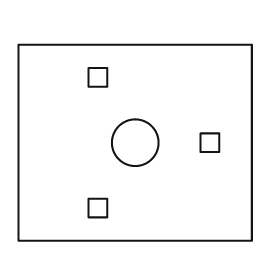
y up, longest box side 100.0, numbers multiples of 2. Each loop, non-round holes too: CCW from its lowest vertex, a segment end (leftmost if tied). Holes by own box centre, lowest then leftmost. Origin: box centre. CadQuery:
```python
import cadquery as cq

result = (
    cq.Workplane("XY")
    .moveTo(-50.0, -42.0)
    .lineTo(50.0, -42.0)
    .lineTo(50.0, 42.0)
    .lineTo(-50.0, 42.0)
    .close()
    .moveTo(-20.0, -32.0)
    .lineTo(-12.0, -32.0)
    .lineTo(-12.0, -24.0)
    .lineTo(-20.0, -24.0)
    .close()
    .moveTo(0.0, 0.0)
    .circle(10.0)
    .moveTo(28.0, -4.0)
    .lineTo(36.0, -4.0)
    .lineTo(36.0, 4.0)
    .lineTo(28.0, 4.0)
    .close()
    .moveTo(-20.0, 24.0)
    .lineTo(-12.0, 24.0)
    .lineTo(-12.0, 32.0)
    .lineTo(-20.0, 32.0)
    .close()
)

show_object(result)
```